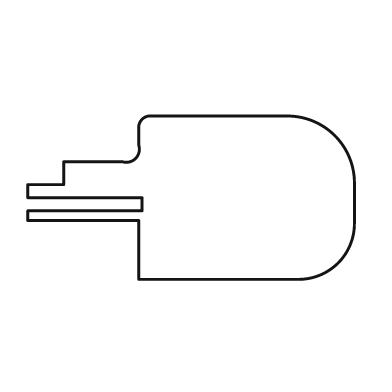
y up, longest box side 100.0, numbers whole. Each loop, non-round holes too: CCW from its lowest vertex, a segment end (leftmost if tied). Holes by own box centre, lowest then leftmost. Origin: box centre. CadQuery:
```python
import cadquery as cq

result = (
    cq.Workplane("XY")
    .moveTo(-16.0, -25.0)
    .lineTo(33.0, -25.0)
    .threePointArc((45.0, -20.0), (50.0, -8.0))
    .lineTo(50.0, 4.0)
    .threePointArc((44.0, 19.0), (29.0, 25.0))
    .lineTo(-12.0, 25.0)
    .threePointArc((-15.0, 24.0), (-16.0, 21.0))
    .lineTo(-16.0, 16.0)
    .threePointArc((-17.0, 12.0), (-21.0, 11.0))
    .lineTo(-39.0, 11.0)
    .lineTo(-39.0, 4.0)
    .lineTo(-50.0, 4.0)
    .lineTo(-50.0, 0.0)
    .lineTo(-15.0, 0.0)
    .lineTo(-15.0, -4.0)
    .lineTo(-50.0, -4.0)
    .lineTo(-50.0, -7.0)
    .lineTo(-16.0, -7.0)
    .close()
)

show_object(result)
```